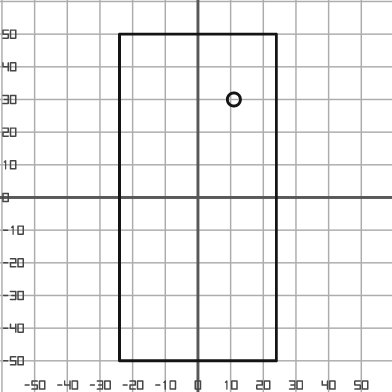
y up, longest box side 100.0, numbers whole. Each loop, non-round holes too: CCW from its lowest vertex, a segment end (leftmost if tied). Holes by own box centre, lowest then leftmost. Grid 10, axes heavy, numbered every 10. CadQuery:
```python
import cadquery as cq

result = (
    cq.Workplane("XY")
    .moveTo(-24.0, -50.0)
    .lineTo(24.0, -50.0)
    .lineTo(24.0, 50.0)
    .lineTo(-24.0, 50.0)
    .close()
    .moveTo(11.0, 30.0)
    .circle(2.0)
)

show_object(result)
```